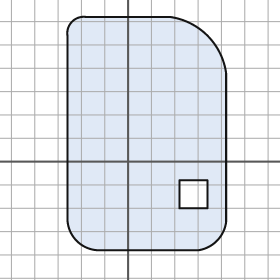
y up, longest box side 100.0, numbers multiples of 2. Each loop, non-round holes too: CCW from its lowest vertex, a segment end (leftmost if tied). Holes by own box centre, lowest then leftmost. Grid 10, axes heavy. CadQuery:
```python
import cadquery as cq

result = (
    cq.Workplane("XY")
    .moveTo(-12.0, -38.0)
    .lineTo(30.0, -38.0)
    .threePointArc((38.0, -34.0), (42.0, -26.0))
    .lineTo(42.0, 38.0)
    .threePointArc((34.0, 54.0), (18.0, 62.0))
    .lineTo(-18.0, 62.0)
    .threePointArc((-24.0, 60.0), (-26.0, 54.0))
    .lineTo(-26.0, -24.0)
    .threePointArc((-22.0, -34.0), (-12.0, -38.0))
    .close()
    .moveTo(22.0, -20.0)
    .lineTo(34.0, -20.0)
    .lineTo(34.0, -8.0)
    .lineTo(22.0, -8.0)
    .close()
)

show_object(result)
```